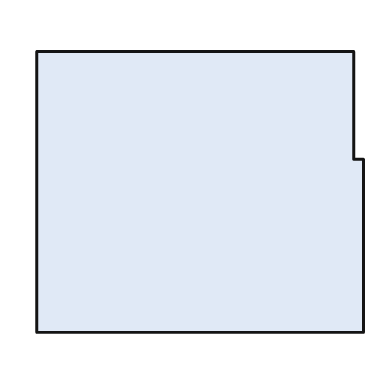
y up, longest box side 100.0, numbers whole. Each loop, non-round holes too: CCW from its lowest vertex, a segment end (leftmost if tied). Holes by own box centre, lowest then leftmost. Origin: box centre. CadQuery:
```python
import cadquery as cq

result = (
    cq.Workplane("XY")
    .moveTo(-50.0, -43.0)
    .lineTo(50.0, -43.0)
    .lineTo(50.0, 10.0)
    .lineTo(47.0, 10.0)
    .lineTo(47.0, 43.0)
    .lineTo(-50.0, 43.0)
    .close()
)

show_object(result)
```